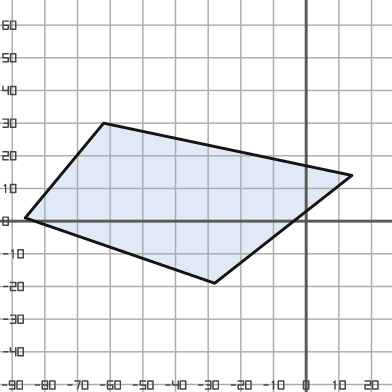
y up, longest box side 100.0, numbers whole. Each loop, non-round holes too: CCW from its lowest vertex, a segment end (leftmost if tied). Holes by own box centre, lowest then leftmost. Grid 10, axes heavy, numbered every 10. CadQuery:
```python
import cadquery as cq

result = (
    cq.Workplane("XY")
    .moveTo(-28.0, -19.0)
    .lineTo(14.0, 14.0)
    .lineTo(-62.0, 30.0)
    .lineTo(-86.0, 1.0)
    .close()
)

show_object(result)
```